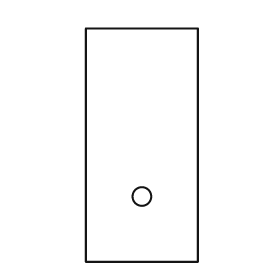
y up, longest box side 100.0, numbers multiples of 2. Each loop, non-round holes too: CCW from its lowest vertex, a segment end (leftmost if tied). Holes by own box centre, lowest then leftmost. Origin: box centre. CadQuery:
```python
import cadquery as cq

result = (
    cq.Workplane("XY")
    .moveTo(-24.0, -50.0)
    .lineTo(24.0, -50.0)
    .lineTo(24.0, 50.0)
    .lineTo(-24.0, 50.0)
    .close()
    .moveTo(0.0, -22.0)
    .circle(4.0)
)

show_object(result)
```